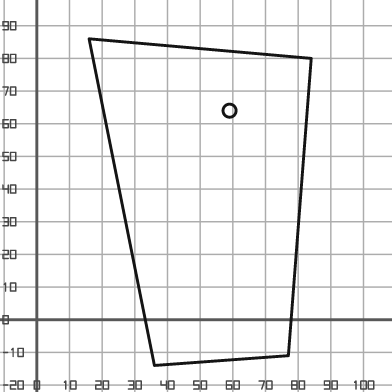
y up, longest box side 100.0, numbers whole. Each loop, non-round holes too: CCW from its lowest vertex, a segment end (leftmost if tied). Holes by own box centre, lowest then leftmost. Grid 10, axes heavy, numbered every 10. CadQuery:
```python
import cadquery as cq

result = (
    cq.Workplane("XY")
    .moveTo(36.0, -14.0)
    .lineTo(77.0, -11.0)
    .lineTo(84.0, 80.0)
    .lineTo(16.0, 86.0)
    .close()
    .moveTo(59.0, 64.0)
    .circle(2.0)
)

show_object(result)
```